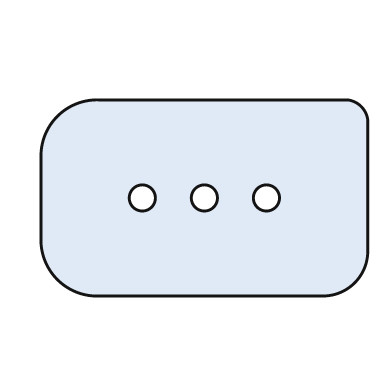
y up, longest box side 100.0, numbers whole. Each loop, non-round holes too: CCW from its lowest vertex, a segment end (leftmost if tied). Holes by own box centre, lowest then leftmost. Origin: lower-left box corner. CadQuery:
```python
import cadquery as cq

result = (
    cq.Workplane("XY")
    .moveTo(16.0, 0.0)
    .lineTo(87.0, 0.0)
    .threePointArc((96.0, 4.0), (100.0, 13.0))
    .lineTo(100.0, 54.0)
    .threePointArc((98.0, 58.0), (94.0, 60.0))
    .lineTo(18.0, 60.0)
    .threePointArc((5.0, 55.0), (0.0, 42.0))
    .lineTo(0.0, 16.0)
    .threePointArc((5.0, 5.0), (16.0, 0.0))
    .close()
    .moveTo(31.0, 30.0)
    .circle(4.0)
    .moveTo(50.0, 30.0)
    .circle(4.0)
    .moveTo(69.0, 30.0)
    .circle(4.0)
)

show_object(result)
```